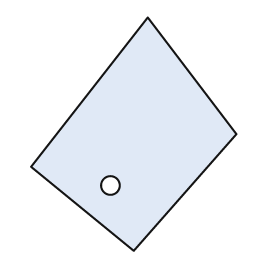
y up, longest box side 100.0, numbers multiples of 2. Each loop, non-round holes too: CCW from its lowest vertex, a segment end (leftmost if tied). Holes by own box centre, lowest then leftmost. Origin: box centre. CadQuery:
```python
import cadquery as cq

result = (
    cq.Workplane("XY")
    .moveTo(0.0, -50.0)
    .lineTo(44.0, 0.0)
    .lineTo(6.0, 50.0)
    .lineTo(-44.0, -14.0)
    .close()
    .moveTo(-10.0, -22.0)
    .circle(4.0)
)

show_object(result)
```